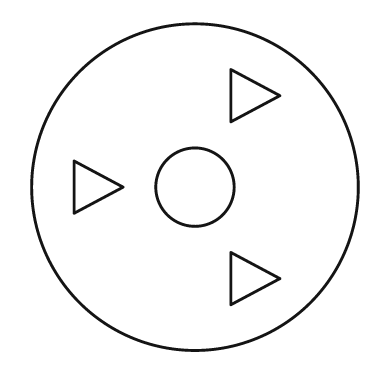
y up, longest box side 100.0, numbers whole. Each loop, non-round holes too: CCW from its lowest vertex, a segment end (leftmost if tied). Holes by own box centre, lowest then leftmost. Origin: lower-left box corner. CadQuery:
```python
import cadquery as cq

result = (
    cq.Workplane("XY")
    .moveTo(50.0, 50.0)
    .circle(50.0)
    .moveTo(61.0, 14.0)
    .lineTo(76.0, 22.0)
    .lineTo(61.0, 30.0)
    .close()
    .moveTo(13.0, 42.0)
    .lineTo(28.0, 50.0)
    .lineTo(13.0, 58.0)
    .close()
    .moveTo(50.0, 50.0)
    .circle(12.0)
    .moveTo(61.0, 70.0)
    .lineTo(76.0, 78.0)
    .lineTo(61.0, 86.0)
    .close()
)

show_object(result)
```